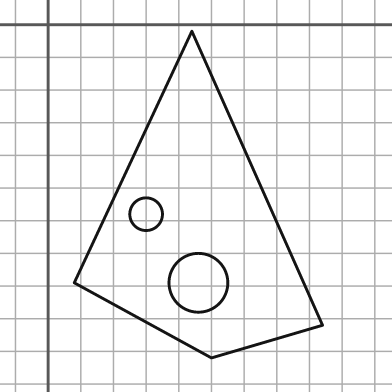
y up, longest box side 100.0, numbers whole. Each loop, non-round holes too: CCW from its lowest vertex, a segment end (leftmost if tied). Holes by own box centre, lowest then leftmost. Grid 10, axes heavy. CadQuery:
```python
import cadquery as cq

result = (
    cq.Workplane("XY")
    .moveTo(50.0, -102.0)
    .lineTo(84.0, -92.0)
    .lineTo(44.0, -2.0)
    .lineTo(8.0, -79.0)
    .close()
    .moveTo(46.0, -79.0)
    .circle(9.0)
    .moveTo(30.0, -58.0)
    .circle(5.0)
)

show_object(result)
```